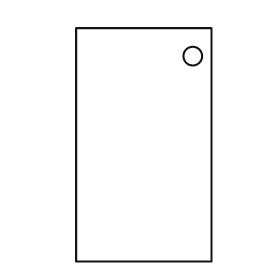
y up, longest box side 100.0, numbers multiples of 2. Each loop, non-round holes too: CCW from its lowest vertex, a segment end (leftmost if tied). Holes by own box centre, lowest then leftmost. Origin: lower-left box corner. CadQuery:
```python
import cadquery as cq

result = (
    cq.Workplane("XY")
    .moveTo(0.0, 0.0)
    .lineTo(58.0, 0.0)
    .lineTo(58.0, 100.0)
    .lineTo(0.0, 100.0)
    .close()
    .moveTo(50.0, 88.0)
    .circle(4.0)
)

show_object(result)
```